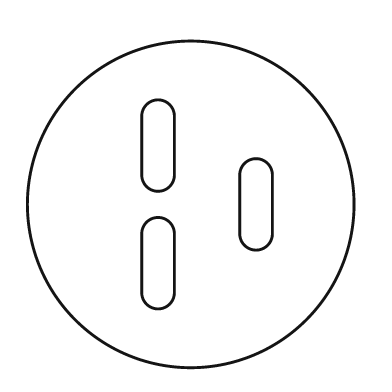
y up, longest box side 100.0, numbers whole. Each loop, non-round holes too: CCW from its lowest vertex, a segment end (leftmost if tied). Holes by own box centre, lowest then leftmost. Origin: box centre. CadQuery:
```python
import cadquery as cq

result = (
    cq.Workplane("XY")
    .moveTo(0.0, 0.0)
    .circle(50.0)
    .moveTo(-15.0, -27.0)
    .threePointArc((-10.0, -32.0), (-5.0, -27.0))
    .lineTo(-5.0, -9.0)
    .threePointArc((-10.0, -4.0), (-15.0, -9.0))
    .close()
    .moveTo(15.0, -9.0)
    .threePointArc((20.0, -14.0), (25.0, -9.0))
    .lineTo(25.0, 9.0)
    .threePointArc((20.0, 14.0), (15.0, 9.0))
    .close()
    .moveTo(-15.0, 9.0)
    .threePointArc((-10.0, 4.0), (-5.0, 9.0))
    .lineTo(-5.0, 27.0)
    .threePointArc((-10.0, 32.0), (-15.0, 27.0))
    .close()
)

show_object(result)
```